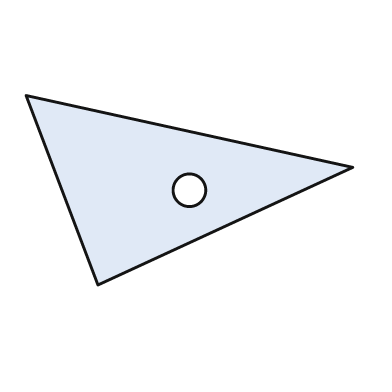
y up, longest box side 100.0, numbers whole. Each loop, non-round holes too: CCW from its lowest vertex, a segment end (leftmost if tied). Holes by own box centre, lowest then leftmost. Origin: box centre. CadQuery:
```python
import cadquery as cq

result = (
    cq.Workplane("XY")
    .moveTo(-28.0, -29.0)
    .lineTo(50.0, 7.0)
    .lineTo(-50.0, 29.0)
    .close()
    .moveTo(0.0, 0.0)
    .circle(5.0)
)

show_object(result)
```